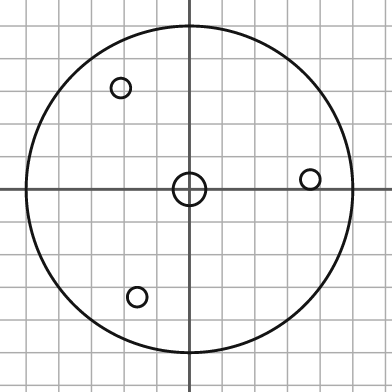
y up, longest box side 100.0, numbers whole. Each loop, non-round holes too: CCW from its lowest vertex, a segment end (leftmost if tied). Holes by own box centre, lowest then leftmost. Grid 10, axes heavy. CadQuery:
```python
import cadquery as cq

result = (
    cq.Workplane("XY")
    .moveTo(0.0, 0.0)
    .circle(50.0)
    .moveTo(-16.0, -33.0)
    .circle(3.0)
    .moveTo(0.0, 0.0)
    .circle(5.0)
    .moveTo(37.0, 3.0)
    .circle(3.0)
    .moveTo(-21.0, 31.0)
    .circle(3.0)
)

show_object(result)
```